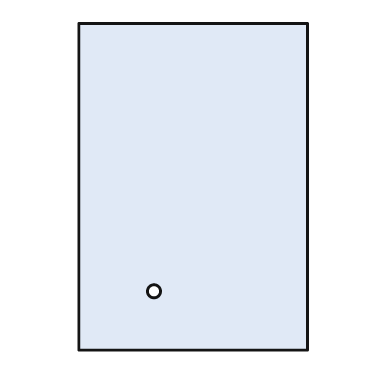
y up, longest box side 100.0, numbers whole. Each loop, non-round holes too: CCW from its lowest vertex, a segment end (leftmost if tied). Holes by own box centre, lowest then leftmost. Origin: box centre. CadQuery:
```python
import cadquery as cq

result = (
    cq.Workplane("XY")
    .moveTo(-35.0, -50.0)
    .lineTo(35.0, -50.0)
    .lineTo(35.0, 50.0)
    .lineTo(-35.0, 50.0)
    .close()
    .moveTo(-12.0, -32.0)
    .circle(2.0)
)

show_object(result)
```